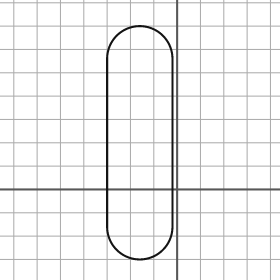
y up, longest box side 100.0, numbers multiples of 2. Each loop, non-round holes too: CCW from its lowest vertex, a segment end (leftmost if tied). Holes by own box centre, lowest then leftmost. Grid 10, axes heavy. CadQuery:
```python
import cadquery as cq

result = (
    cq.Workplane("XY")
    .moveTo(-30.0, -16.0)
    .threePointArc((-16.0, -30.0), (-2.0, -16.0))
    .lineTo(-2.0, 56.0)
    .threePointArc((-16.0, 70.0), (-30.0, 56.0))
    .close()
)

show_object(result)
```